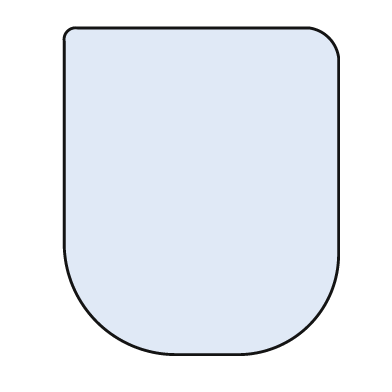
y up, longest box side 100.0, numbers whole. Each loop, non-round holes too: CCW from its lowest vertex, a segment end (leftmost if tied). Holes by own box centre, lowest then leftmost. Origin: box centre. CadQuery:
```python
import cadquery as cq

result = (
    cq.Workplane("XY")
    .moveTo(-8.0, -50.0)
    .lineTo(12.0, -50.0)
    .threePointArc((33.0, -41.0), (42.0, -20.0))
    .lineTo(42.0, 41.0)
    .threePointArc((39.0, 47.0), (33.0, 50.0))
    .lineTo(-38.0, 50.0)
    .threePointArc((-41.0, 49.0), (-42.0, 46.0))
    .lineTo(-42.0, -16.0)
    .threePointArc((-32.0, -40.0), (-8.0, -50.0))
    .close()
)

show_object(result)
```